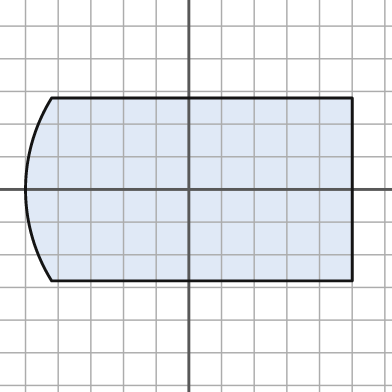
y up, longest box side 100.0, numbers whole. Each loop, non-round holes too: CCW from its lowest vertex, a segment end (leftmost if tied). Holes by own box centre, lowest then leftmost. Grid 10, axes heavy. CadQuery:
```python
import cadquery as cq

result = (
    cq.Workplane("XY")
    .moveTo(-42.0, -28.0)
    .lineTo(50.0, -28.0)
    .lineTo(50.0, 28.0)
    .lineTo(-42.0, 28.0)
    .threePointArc((-50.0, 0.0), (-42.0, -28.0))
    .close()
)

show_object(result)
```